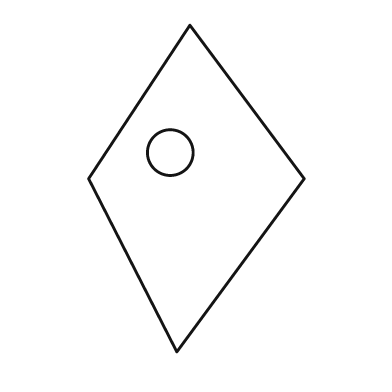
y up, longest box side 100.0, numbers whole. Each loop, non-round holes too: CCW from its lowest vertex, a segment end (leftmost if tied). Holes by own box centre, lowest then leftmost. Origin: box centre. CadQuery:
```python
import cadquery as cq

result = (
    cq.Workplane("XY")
    .moveTo(-6.0, -50.0)
    .lineTo(33.0, 3.0)
    .lineTo(-2.0, 50.0)
    .lineTo(-33.0, 3.0)
    .close()
    .moveTo(-8.0, 11.0)
    .circle(7.0)
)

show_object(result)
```